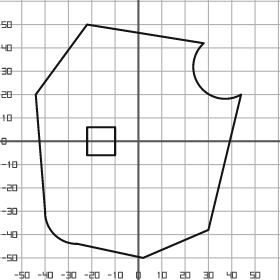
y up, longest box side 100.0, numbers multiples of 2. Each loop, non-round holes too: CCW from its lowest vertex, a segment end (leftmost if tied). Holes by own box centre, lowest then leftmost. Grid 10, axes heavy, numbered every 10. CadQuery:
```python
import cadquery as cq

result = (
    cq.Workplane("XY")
    .moveTo(2.0, -50.0)
    .lineTo(30.0, -38.0)
    .lineTo(44.0, 20.0)
    .threePointArc((26.0, 24.0), (28.0, 42.0))
    .lineTo(-22.0, 50.0)
    .lineTo(-44.0, 20.0)
    .lineTo(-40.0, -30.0)
    .threePointArc((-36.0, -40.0), (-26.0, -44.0))
    .close()
    .moveTo(-22.0, -6.0)
    .lineTo(-10.0, -6.0)
    .lineTo(-10.0, 6.0)
    .lineTo(-22.0, 6.0)
    .close()
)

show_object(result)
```